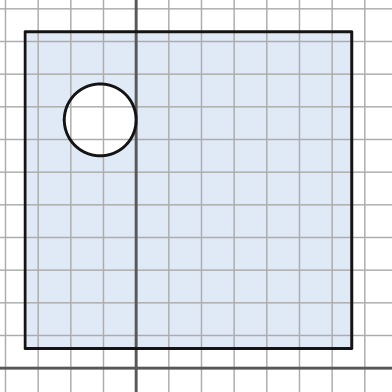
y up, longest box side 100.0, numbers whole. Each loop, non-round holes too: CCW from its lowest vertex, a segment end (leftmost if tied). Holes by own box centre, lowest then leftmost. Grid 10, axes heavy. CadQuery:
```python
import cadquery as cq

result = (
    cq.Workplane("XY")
    .moveTo(-34.0, 6.0)
    .lineTo(66.0, 6.0)
    .lineTo(66.0, 103.0)
    .lineTo(-34.0, 103.0)
    .close()
    .moveTo(-11.0, 76.0)
    .circle(11.0)
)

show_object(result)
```